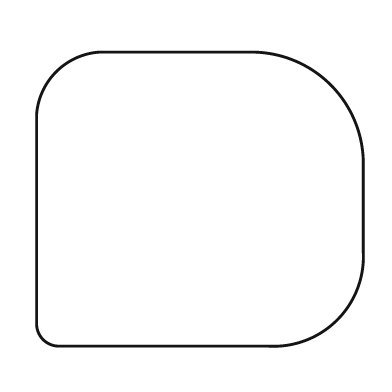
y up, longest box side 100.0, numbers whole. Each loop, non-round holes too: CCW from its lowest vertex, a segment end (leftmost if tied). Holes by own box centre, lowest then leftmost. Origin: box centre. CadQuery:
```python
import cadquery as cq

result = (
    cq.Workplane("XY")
    .moveTo(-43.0, -45.0)
    .lineTo(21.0, -45.0)
    .threePointArc((42.0, -37.0), (50.0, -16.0))
    .lineTo(50.0, 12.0)
    .threePointArc((40.0, 35.0), (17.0, 45.0))
    .lineTo(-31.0, 45.0)
    .threePointArc((-44.0, 39.0), (-50.0, 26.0))
    .lineTo(-50.0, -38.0)
    .threePointArc((-48.0, -43.0), (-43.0, -45.0))
    .close()
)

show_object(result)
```